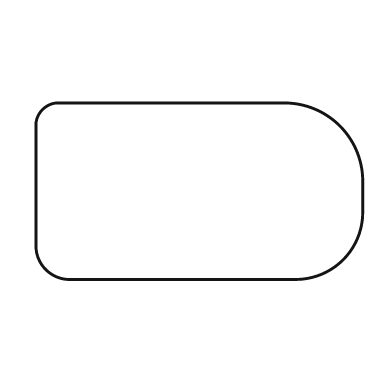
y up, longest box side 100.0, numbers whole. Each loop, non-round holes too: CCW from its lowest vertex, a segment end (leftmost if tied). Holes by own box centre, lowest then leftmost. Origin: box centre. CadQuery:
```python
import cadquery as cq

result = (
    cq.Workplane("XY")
    .moveTo(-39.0, -27.0)
    .lineTo(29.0, -27.0)
    .threePointArc((44.0, -21.0), (50.0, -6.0))
    .lineTo(50.0, 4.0)
    .threePointArc((43.0, 20.0), (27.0, 27.0))
    .lineTo(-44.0, 27.0)
    .threePointArc((-48.0, 25.0), (-50.0, 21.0))
    .lineTo(-50.0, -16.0)
    .threePointArc((-47.0, -24.0), (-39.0, -27.0))
    .close()
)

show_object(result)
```